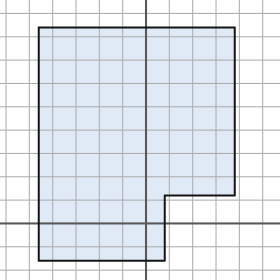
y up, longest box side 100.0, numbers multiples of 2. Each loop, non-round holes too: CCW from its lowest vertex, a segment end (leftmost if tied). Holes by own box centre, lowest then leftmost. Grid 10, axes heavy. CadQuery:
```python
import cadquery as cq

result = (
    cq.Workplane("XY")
    .moveTo(-46.0, -16.0)
    .lineTo(8.0, -16.0)
    .lineTo(8.0, 12.0)
    .lineTo(38.0, 12.0)
    .lineTo(38.0, 84.0)
    .lineTo(-46.0, 84.0)
    .close()
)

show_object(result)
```